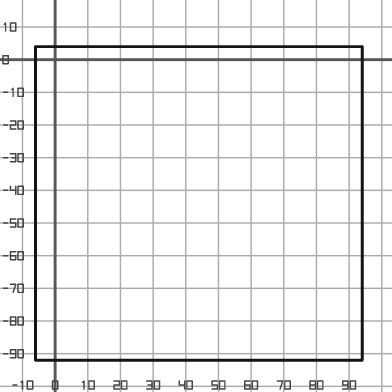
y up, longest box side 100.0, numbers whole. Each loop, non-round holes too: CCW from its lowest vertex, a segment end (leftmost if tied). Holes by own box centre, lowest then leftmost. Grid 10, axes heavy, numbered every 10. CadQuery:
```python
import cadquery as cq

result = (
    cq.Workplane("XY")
    .moveTo(-6.0, -92.0)
    .lineTo(94.0, -92.0)
    .lineTo(94.0, 4.0)
    .lineTo(-6.0, 4.0)
    .close()
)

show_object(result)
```